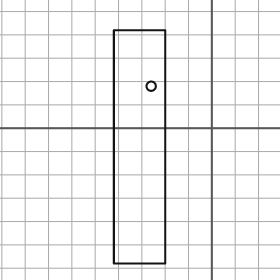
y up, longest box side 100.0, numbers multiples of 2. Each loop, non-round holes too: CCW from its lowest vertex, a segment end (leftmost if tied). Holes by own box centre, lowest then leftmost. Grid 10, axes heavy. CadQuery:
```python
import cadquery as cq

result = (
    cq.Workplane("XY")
    .moveTo(-42.0, -58.0)
    .lineTo(-20.0, -58.0)
    .lineTo(-20.0, 42.0)
    .lineTo(-42.0, 42.0)
    .close()
    .moveTo(-26.0, 18.0)
    .circle(2.0)
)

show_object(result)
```